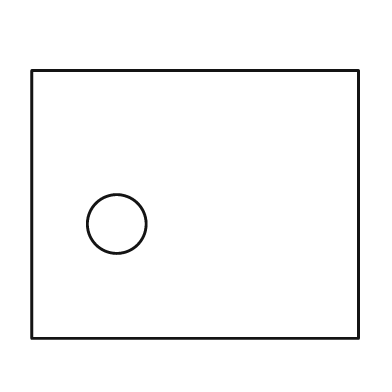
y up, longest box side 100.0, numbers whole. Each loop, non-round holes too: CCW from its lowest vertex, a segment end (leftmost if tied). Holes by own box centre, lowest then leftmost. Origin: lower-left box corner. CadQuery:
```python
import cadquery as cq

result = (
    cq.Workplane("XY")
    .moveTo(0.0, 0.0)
    .lineTo(100.0, 0.0)
    .lineTo(100.0, 82.0)
    .lineTo(0.0, 82.0)
    .close()
    .moveTo(26.0, 35.0)
    .circle(9.0)
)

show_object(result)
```